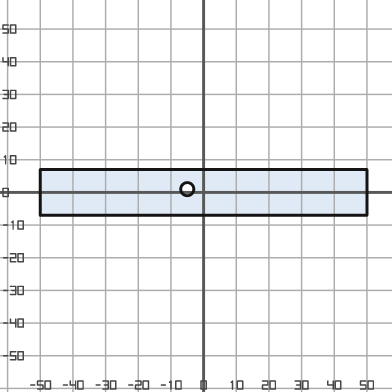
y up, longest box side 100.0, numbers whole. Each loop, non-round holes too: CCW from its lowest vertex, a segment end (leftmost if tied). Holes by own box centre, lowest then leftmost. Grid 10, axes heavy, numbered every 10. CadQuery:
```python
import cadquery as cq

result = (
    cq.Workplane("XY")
    .moveTo(-50.0, -7.0)
    .lineTo(50.0, -7.0)
    .lineTo(50.0, 7.0)
    .lineTo(-50.0, 7.0)
    .close()
    .moveTo(-5.0, 1.0)
    .circle(2.0)
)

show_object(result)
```